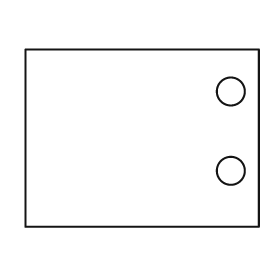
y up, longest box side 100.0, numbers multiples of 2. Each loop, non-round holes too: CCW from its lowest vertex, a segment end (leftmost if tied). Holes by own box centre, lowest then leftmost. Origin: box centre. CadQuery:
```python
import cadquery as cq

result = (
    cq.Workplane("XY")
    .moveTo(-50.0, -38.0)
    .lineTo(50.0, -38.0)
    .lineTo(50.0, 38.0)
    .lineTo(-50.0, 38.0)
    .close()
    .moveTo(38.0, -14.0)
    .circle(6.0)
    .moveTo(38.0, 20.0)
    .circle(6.0)
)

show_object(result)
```